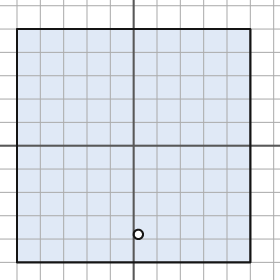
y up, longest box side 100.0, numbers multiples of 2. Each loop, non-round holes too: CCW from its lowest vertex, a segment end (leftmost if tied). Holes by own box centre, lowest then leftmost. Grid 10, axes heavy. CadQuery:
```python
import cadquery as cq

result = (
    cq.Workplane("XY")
    .moveTo(-50.0, -50.0)
    .lineTo(50.0, -50.0)
    .lineTo(50.0, 50.0)
    .lineTo(-50.0, 50.0)
    .close()
    .moveTo(2.0, -38.0)
    .circle(2.0)
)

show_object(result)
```